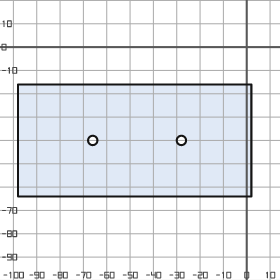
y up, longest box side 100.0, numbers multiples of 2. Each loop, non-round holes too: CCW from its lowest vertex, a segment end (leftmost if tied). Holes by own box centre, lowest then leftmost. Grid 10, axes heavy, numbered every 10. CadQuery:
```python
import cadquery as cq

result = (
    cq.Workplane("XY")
    .moveTo(-98.0, -64.0)
    .lineTo(2.0, -64.0)
    .lineTo(2.0, -16.0)
    .lineTo(-98.0, -16.0)
    .close()
    .moveTo(-66.0, -40.0)
    .circle(2.0)
    .moveTo(-28.0, -40.0)
    .circle(2.0)
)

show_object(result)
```